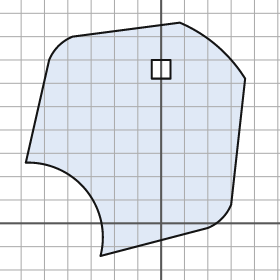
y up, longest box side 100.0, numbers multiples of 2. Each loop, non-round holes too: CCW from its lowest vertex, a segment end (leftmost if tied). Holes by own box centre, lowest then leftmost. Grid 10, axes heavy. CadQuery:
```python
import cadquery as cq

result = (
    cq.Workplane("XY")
    .moveTo(-26.0, -14.0)
    .lineTo(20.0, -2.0)
    .threePointArc((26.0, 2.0), (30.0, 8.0))
    .lineTo(36.0, 62.0)
    .threePointArc((24.0, 76.0), (8.0, 86.0))
    .lineTo(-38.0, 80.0)
    .threePointArc((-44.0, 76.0), (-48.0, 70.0))
    .lineTo(-58.0, 26.0)
    .threePointArc((-32.0, 14.0), (-26.0, -14.0))
    .close()
    .moveTo(-4.0, 62.0)
    .lineTo(4.0, 62.0)
    .lineTo(4.0, 70.0)
    .lineTo(-4.0, 70.0)
    .close()
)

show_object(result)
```